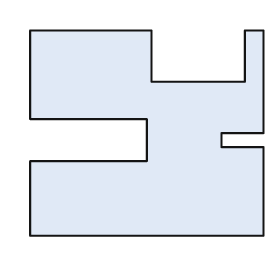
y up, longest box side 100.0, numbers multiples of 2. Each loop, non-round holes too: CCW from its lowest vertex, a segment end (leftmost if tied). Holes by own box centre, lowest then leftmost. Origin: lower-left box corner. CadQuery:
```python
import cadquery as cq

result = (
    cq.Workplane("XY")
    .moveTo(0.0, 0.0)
    .lineTo(100.0, 0.0)
    .lineTo(100.0, 38.0)
    .lineTo(82.0, 38.0)
    .lineTo(82.0, 44.0)
    .lineTo(100.0, 44.0)
    .lineTo(100.0, 88.0)
    .lineTo(92.0, 88.0)
    .lineTo(92.0, 66.0)
    .lineTo(52.0, 66.0)
    .lineTo(52.0, 88.0)
    .lineTo(0.0, 88.0)
    .lineTo(0.0, 50.0)
    .lineTo(50.0, 50.0)
    .lineTo(50.0, 32.0)
    .lineTo(0.0, 32.0)
    .close()
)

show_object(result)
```